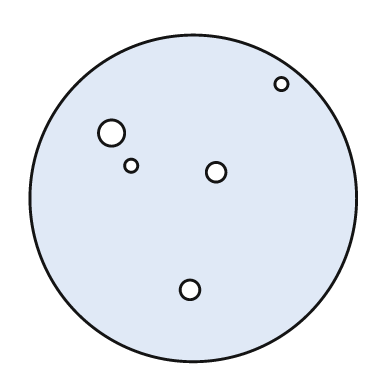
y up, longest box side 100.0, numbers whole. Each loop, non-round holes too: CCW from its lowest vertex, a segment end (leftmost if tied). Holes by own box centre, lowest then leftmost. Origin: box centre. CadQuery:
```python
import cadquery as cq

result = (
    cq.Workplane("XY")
    .moveTo(0.0, 0.0)
    .circle(50.0)
    .moveTo(-1.0, -28.0)
    .circle(3.0)
    .moveTo(7.0, 8.0)
    .circle(3.0)
    .moveTo(-19.0, 10.0)
    .circle(2.0)
    .moveTo(-25.0, 20.0)
    .circle(4.0)
    .moveTo(27.0, 35.0)
    .circle(2.0)
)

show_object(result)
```